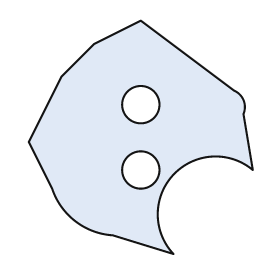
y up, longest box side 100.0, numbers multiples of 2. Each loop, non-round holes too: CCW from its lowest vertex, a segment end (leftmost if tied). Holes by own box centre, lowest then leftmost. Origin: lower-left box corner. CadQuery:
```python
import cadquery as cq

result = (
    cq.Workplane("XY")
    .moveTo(62.0, 0.0)
    .threePointArc((62.0, 34.0), (96.0, 36.0))
    .lineTo(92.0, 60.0)
    .threePointArc((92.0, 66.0), (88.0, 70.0))
    .lineTo(48.0, 100.0)
    .lineTo(28.0, 90.0)
    .lineTo(14.0, 76.0)
    .lineTo(0.0, 48.0)
    .lineTo(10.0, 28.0)
    .threePointArc((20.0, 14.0), (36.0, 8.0))
    .close()
    .moveTo(48.0, 36.0)
    .circle(8.0)
    .moveTo(48.0, 64.0)
    .circle(8.0)
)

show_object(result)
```